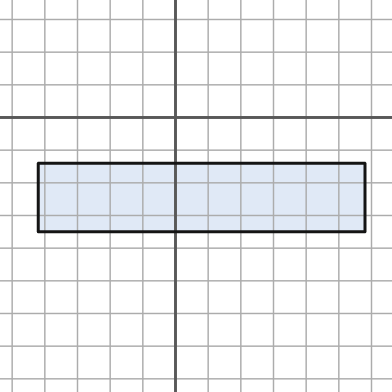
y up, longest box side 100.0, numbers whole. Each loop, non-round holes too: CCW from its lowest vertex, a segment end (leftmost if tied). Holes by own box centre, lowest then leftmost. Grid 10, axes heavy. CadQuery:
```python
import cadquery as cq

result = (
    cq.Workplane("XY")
    .moveTo(-42.0, -35.0)
    .lineTo(58.0, -35.0)
    .lineTo(58.0, -14.0)
    .lineTo(-42.0, -14.0)
    .close()
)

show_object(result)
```